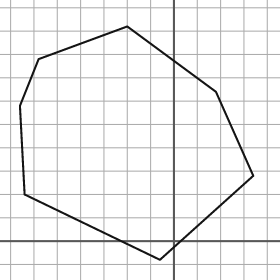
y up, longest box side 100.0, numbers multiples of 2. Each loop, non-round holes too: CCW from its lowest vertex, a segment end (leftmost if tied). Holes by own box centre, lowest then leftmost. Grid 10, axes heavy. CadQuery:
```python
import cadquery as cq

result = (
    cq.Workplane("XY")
    .moveTo(-6.0, -8.0)
    .lineTo(34.0, 28.0)
    .lineTo(18.0, 64.0)
    .lineTo(-20.0, 92.0)
    .lineTo(-58.0, 78.0)
    .lineTo(-66.0, 58.0)
    .lineTo(-64.0, 20.0)
    .close()
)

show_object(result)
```